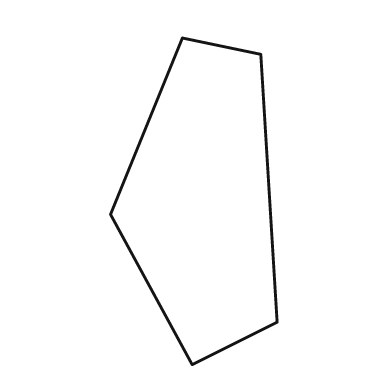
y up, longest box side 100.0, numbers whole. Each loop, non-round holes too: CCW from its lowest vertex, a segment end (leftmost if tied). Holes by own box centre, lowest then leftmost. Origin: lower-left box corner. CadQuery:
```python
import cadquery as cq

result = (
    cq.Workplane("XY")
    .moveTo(25.0, 0.0)
    .lineTo(51.0, 13.0)
    .lineTo(46.0, 95.0)
    .lineTo(22.0, 100.0)
    .lineTo(0.0, 46.0)
    .close()
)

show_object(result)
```